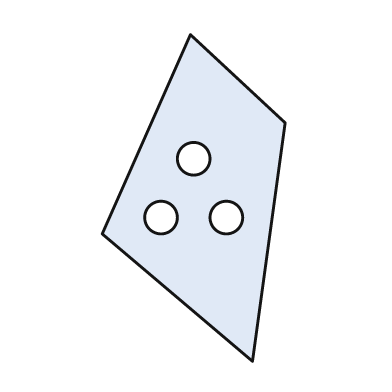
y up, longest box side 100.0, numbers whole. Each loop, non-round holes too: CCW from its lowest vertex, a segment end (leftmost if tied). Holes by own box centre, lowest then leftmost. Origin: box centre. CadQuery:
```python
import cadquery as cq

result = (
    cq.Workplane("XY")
    .moveTo(18.0, -50.0)
    .lineTo(28.0, 23.0)
    .lineTo(-1.0, 50.0)
    .lineTo(-28.0, -11.0)
    .close()
    .moveTo(-10.0, -6.0)
    .circle(5.0)
    .moveTo(10.0, -6.0)
    .circle(5.0)
    .moveTo(0.0, 12.0)
    .circle(5.0)
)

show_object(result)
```